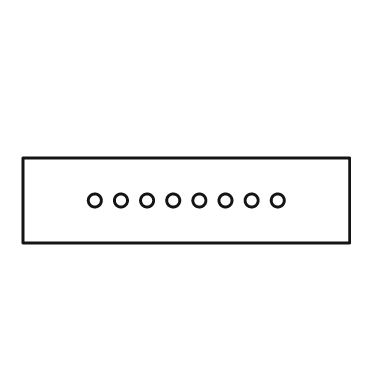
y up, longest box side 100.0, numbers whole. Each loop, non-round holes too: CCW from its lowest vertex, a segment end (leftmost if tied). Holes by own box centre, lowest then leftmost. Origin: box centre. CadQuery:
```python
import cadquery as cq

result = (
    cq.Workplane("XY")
    .moveTo(-50.0, -13.0)
    .lineTo(50.0, -13.0)
    .lineTo(50.0, 13.0)
    .lineTo(-50.0, 13.0)
    .close()
    .moveTo(-28.0, 0.0)
    .circle(2.0)
    .moveTo(-20.0, 0.0)
    .circle(2.0)
    .moveTo(-12.0, 0.0)
    .circle(2.0)
    .moveTo(-4.0, 0.0)
    .circle(2.0)
    .moveTo(4.0, 0.0)
    .circle(2.0)
    .moveTo(12.0, 0.0)
    .circle(2.0)
    .moveTo(20.0, 0.0)
    .circle(2.0)
    .moveTo(28.0, 0.0)
    .circle(2.0)
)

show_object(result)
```